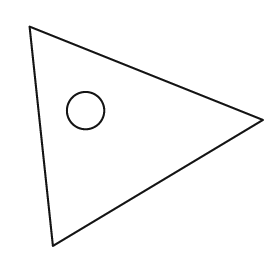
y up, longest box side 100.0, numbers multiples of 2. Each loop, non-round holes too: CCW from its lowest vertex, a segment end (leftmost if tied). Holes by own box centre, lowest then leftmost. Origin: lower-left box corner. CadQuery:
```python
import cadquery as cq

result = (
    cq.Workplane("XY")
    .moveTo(10.0, 0.0)
    .lineTo(100.0, 54.0)
    .lineTo(0.0, 94.0)
    .close()
    .moveTo(24.0, 58.0)
    .circle(8.0)
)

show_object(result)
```